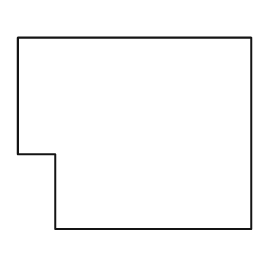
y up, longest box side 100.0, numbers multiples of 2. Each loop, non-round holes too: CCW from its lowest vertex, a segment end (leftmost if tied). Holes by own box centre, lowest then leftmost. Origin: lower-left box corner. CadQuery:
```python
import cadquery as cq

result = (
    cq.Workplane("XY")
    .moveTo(16.0, 0.0)
    .lineTo(100.0, 0.0)
    .lineTo(100.0, 82.0)
    .lineTo(0.0, 82.0)
    .lineTo(0.0, 32.0)
    .lineTo(16.0, 32.0)
    .close()
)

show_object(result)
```